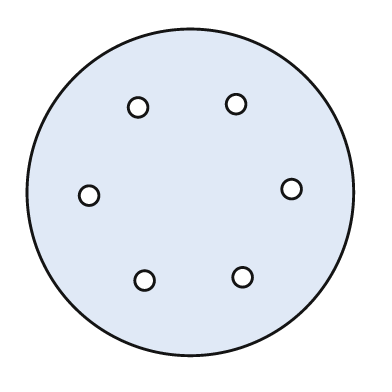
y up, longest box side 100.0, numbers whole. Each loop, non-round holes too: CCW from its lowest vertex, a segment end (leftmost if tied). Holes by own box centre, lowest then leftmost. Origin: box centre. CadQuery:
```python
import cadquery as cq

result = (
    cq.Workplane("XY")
    .moveTo(0.0, 0.0)
    .circle(50.0)
    .moveTo(-14.0, -27.0)
    .circle(3.0)
    .moveTo(16.0, -26.0)
    .circle(3.0)
    .moveTo(-31.0, -1.0)
    .circle(3.0)
    .moveTo(31.0, 1.0)
    .circle(3.0)
    .moveTo(-16.0, 26.0)
    .circle(3.0)
    .moveTo(14.0, 27.0)
    .circle(3.0)
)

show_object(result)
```